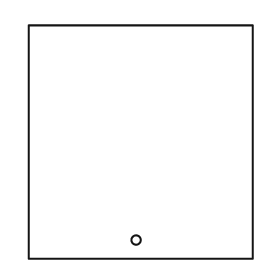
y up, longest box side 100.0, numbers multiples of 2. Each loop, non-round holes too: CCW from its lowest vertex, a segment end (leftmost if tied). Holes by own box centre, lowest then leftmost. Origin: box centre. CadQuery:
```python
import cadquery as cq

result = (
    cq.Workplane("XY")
    .moveTo(-48.0, -50.0)
    .lineTo(48.0, -50.0)
    .lineTo(48.0, 50.0)
    .lineTo(-48.0, 50.0)
    .close()
    .moveTo(-2.0, -42.0)
    .circle(2.0)
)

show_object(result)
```